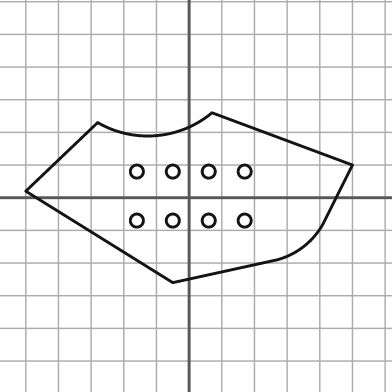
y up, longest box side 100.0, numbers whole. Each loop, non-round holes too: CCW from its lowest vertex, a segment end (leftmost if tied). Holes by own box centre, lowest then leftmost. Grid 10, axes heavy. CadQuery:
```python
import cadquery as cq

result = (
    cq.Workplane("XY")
    .moveTo(-5.0, -26.0)
    .lineTo(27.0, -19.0)
    .threePointArc((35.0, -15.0), (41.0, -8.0))
    .lineTo(50.0, 10.0)
    .lineTo(7.0, 26.0)
    .threePointArc((-10.0, 19.0), (-28.0, 23.0))
    .lineTo(-50.0, 2.0)
    .close()
    .moveTo(-16.0, -7.0)
    .circle(2.0)
    .moveTo(-5.0, -7.0)
    .circle(2.0)
    .moveTo(6.0, -7.0)
    .circle(2.0)
    .moveTo(17.0, -7.0)
    .circle(2.0)
    .moveTo(-16.0, 8.0)
    .circle(2.0)
    .moveTo(-5.0, 8.0)
    .circle(2.0)
    .moveTo(6.0, 8.0)
    .circle(2.0)
    .moveTo(17.0, 8.0)
    .circle(2.0)
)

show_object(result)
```